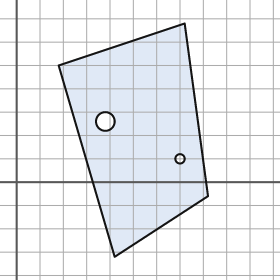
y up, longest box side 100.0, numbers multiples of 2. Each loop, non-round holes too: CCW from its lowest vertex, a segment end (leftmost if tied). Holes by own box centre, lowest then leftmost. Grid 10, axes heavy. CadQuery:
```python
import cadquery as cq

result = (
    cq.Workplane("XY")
    .moveTo(42.0, -32.0)
    .lineTo(82.0, -6.0)
    .lineTo(72.0, 68.0)
    .lineTo(18.0, 50.0)
    .close()
    .moveTo(70.0, 10.0)
    .circle(2.0)
    .moveTo(38.0, 26.0)
    .circle(4.0)
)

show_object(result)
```